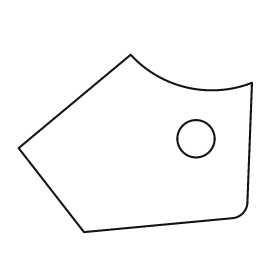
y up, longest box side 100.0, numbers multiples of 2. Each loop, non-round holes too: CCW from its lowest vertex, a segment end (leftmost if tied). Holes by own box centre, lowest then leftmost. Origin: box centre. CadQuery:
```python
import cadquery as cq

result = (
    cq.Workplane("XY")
    .moveTo(-22.0, -38.0)
    .lineTo(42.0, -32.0)
    .threePointArc((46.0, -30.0), (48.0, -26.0))
    .lineTo(50.0, 26.0)
    .threePointArc((22.0, 24.0), (-2.0, 38.0))
    .lineTo(-50.0, -2.0)
    .close()
    .moveTo(26.0, 2.0)
    .circle(8.0)
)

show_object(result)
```